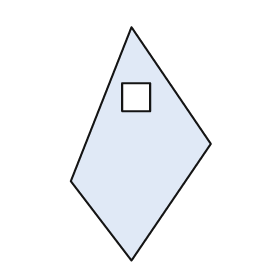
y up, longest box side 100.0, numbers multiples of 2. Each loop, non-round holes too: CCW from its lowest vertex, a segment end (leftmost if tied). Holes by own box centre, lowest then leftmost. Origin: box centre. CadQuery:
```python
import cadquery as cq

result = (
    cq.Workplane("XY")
    .moveTo(-4.0, -50.0)
    .lineTo(30.0, 0.0)
    .lineTo(-4.0, 50.0)
    .lineTo(-30.0, -16.0)
    .close()
    .moveTo(-8.0, 14.0)
    .lineTo(4.0, 14.0)
    .lineTo(4.0, 26.0)
    .lineTo(-8.0, 26.0)
    .close()
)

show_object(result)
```